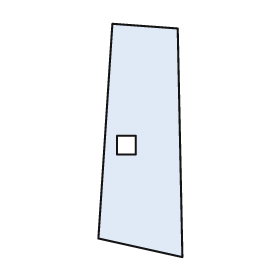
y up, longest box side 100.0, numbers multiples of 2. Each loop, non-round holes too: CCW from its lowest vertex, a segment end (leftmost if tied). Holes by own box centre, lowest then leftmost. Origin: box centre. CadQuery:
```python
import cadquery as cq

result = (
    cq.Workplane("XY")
    .moveTo(18.0, -50.0)
    .lineTo(16.0, 48.0)
    .lineTo(-12.0, 50.0)
    .lineTo(-18.0, -42.0)
    .close()
    .moveTo(-10.0, -6.0)
    .lineTo(-2.0, -6.0)
    .lineTo(-2.0, 2.0)
    .lineTo(-10.0, 2.0)
    .close()
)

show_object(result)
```